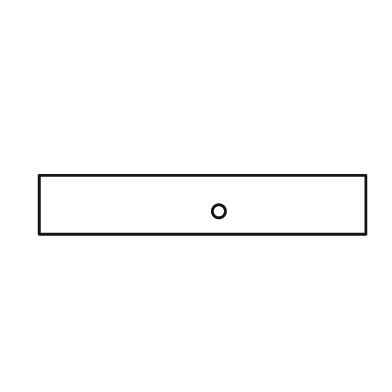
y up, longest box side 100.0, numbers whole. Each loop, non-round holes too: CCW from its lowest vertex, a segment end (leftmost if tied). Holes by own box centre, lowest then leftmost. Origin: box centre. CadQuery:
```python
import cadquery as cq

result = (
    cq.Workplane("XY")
    .moveTo(-50.0, -9.0)
    .lineTo(50.0, -9.0)
    .lineTo(50.0, 9.0)
    .lineTo(-50.0, 9.0)
    .close()
    .moveTo(5.0, -2.0)
    .circle(2.0)
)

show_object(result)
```